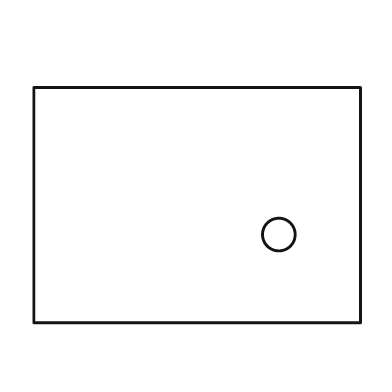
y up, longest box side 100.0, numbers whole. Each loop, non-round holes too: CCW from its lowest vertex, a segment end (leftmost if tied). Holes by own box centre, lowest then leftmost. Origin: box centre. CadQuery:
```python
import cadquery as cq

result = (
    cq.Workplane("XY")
    .moveTo(-50.0, -36.0)
    .lineTo(50.0, -36.0)
    .lineTo(50.0, 36.0)
    .lineTo(-50.0, 36.0)
    .close()
    .moveTo(25.0, -9.0)
    .circle(5.0)
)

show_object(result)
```